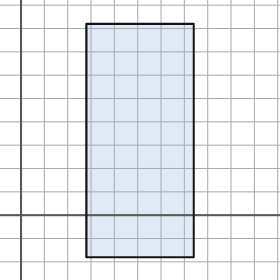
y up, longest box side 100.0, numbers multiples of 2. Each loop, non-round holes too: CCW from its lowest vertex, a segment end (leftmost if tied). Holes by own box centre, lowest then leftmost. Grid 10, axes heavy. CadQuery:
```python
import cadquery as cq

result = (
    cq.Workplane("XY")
    .moveTo(28.0, -18.0)
    .lineTo(74.0, -18.0)
    .lineTo(74.0, 82.0)
    .lineTo(28.0, 82.0)
    .close()
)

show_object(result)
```